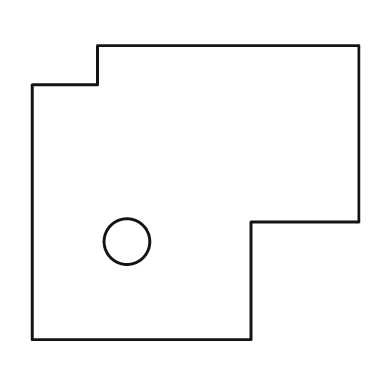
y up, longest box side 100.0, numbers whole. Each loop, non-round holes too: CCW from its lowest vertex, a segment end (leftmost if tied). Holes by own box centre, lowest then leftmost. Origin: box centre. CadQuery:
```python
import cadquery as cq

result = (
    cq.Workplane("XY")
    .moveTo(-50.0, -45.0)
    .lineTo(17.0, -45.0)
    .lineTo(17.0, -9.0)
    .lineTo(50.0, -9.0)
    .lineTo(50.0, 45.0)
    .lineTo(-30.0, 45.0)
    .lineTo(-30.0, 33.0)
    .lineTo(-50.0, 33.0)
    .close()
    .moveTo(-21.0, -15.0)
    .circle(7.0)
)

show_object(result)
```